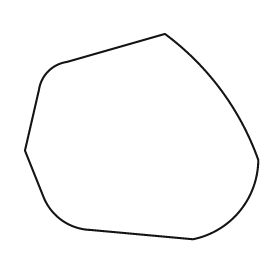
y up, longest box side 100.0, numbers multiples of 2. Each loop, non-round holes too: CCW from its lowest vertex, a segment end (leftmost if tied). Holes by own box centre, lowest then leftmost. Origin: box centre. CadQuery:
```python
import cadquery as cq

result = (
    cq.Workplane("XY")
    .moveTo(22.0, -44.0)
    .threePointArc((42.0, -32.0), (50.0, -10.0))
    .threePointArc((34.0, 20.0), (10.0, 44.0))
    .lineTo(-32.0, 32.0)
    .threePointArc((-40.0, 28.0), (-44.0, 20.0))
    .lineTo(-50.0, -6.0)
    .lineTo(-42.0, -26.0)
    .threePointArc((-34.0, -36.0), (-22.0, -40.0))
    .close()
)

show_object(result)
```